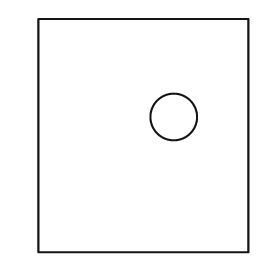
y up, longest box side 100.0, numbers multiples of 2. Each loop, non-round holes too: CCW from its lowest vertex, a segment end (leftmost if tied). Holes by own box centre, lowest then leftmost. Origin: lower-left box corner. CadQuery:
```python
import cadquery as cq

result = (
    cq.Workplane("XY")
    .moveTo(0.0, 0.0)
    .lineTo(90.0, 0.0)
    .lineTo(90.0, 100.0)
    .lineTo(0.0, 100.0)
    .close()
    .moveTo(58.0, 58.0)
    .circle(10.0)
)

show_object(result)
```